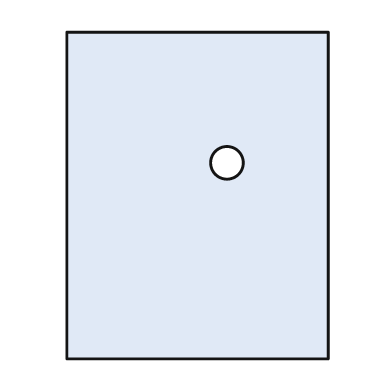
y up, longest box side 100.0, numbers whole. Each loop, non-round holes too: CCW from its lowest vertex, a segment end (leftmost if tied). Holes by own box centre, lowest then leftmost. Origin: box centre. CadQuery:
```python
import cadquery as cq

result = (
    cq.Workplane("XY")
    .moveTo(-40.0, -50.0)
    .lineTo(40.0, -50.0)
    .lineTo(40.0, 50.0)
    .lineTo(-40.0, 50.0)
    .close()
    .moveTo(9.0, 10.0)
    .circle(5.0)
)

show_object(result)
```